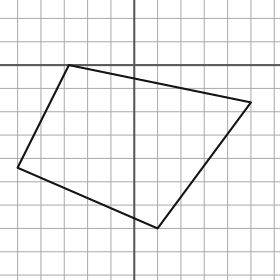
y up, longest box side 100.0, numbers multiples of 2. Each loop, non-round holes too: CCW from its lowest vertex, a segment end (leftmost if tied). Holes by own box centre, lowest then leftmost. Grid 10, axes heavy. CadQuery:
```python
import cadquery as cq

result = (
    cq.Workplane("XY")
    .moveTo(10.0, -70.0)
    .lineTo(50.0, -16.0)
    .lineTo(-28.0, 0.0)
    .lineTo(-50.0, -44.0)
    .close()
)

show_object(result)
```